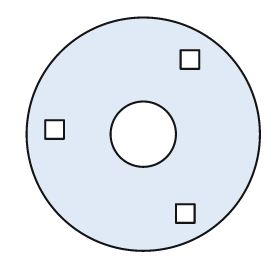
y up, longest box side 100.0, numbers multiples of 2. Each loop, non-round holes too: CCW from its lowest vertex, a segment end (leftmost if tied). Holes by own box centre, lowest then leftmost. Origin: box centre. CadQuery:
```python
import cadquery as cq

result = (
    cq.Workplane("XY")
    .moveTo(0.0, 0.0)
    .circle(50.0)
    .moveTo(14.0, -38.0)
    .lineTo(22.0, -38.0)
    .lineTo(22.0, -30.0)
    .lineTo(14.0, -30.0)
    .close()
    .moveTo(0.0, 0.0)
    .circle(14.0)
    .moveTo(-42.0, -2.0)
    .lineTo(-34.0, -2.0)
    .lineTo(-34.0, 6.0)
    .lineTo(-42.0, 6.0)
    .close()
    .moveTo(16.0, 28.0)
    .lineTo(24.0, 28.0)
    .lineTo(24.0, 36.0)
    .lineTo(16.0, 36.0)
    .close()
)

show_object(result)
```